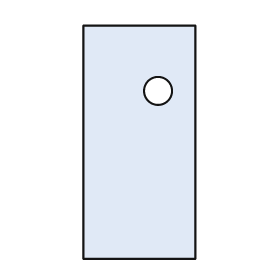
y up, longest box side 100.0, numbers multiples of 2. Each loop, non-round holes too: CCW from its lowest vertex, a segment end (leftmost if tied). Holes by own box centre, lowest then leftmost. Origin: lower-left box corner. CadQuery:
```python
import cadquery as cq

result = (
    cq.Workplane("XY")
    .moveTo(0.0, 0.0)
    .lineTo(48.0, 0.0)
    .lineTo(48.0, 100.0)
    .lineTo(0.0, 100.0)
    .close()
    .moveTo(32.0, 72.0)
    .circle(6.0)
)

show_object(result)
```